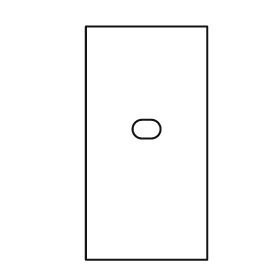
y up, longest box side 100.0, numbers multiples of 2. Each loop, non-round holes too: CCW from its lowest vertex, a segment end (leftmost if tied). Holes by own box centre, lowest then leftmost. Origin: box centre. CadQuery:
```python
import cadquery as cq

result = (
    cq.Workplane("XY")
    .moveTo(-26.0, -50.0)
    .lineTo(26.0, -50.0)
    .lineTo(26.0, 50.0)
    .lineTo(-26.0, 50.0)
    .close()
    .moveTo(-2.0, 2.0)
    .lineTo(2.0, 2.0)
    .threePointArc((6.0, 6.0), (2.0, 10.0))
    .lineTo(-2.0, 10.0)
    .threePointArc((-6.0, 6.0), (-2.0, 2.0))
    .close()
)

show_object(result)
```